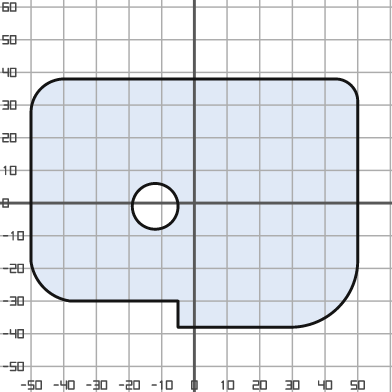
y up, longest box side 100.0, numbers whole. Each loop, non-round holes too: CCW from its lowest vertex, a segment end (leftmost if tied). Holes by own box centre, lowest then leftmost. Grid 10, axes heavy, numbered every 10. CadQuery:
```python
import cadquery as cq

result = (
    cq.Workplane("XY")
    .moveTo(-5.0, -38.0)
    .lineTo(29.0, -38.0)
    .threePointArc((44.0, -32.0), (50.0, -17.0))
    .lineTo(50.0, 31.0)
    .threePointArc((48.0, 36.0), (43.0, 38.0))
    .lineTo(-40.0, 38.0)
    .threePointArc((-47.0, 35.0), (-50.0, 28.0))
    .lineTo(-50.0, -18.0)
    .threePointArc((-46.0, -26.0), (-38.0, -30.0))
    .lineTo(-5.0, -30.0)
    .close()
    .moveTo(-12.0, -1.0)
    .circle(7.0)
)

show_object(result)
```